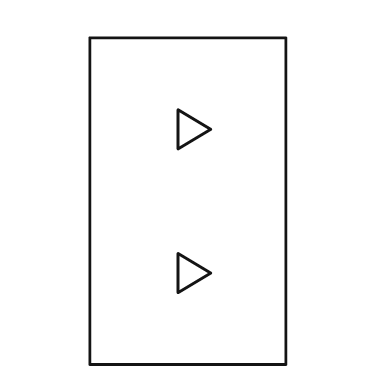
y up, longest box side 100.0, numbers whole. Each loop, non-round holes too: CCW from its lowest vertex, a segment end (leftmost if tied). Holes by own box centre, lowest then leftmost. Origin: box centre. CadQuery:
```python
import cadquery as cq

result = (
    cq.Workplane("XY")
    .moveTo(-30.0, -50.0)
    .lineTo(30.0, -50.0)
    .lineTo(30.0, 50.0)
    .lineTo(-30.0, 50.0)
    .close()
    .moveTo(-3.0, -28.0)
    .lineTo(7.0, -22.0)
    .lineTo(-3.0, -16.0)
    .close()
    .moveTo(-3.0, 16.0)
    .lineTo(7.0, 22.0)
    .lineTo(-3.0, 28.0)
    .close()
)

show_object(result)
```